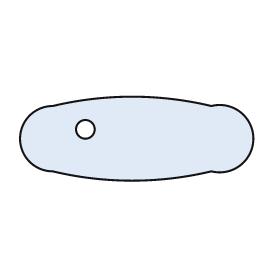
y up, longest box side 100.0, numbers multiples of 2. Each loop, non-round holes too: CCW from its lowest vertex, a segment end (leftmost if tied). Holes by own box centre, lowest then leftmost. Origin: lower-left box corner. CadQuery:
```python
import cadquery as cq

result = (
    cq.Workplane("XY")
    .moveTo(14.0, 4.0)
    .threePointArc((48.0, 0.0), (82.0, 4.0))
    .threePointArc((100.0, 18.0), (82.0, 32.0))
    .threePointArc((48.0, 36.0), (14.0, 32.0))
    .threePointArc((0.0, 18.0), (14.0, 4.0))
    .close()
    .moveTo(28.0, 22.0)
    .circle(4.0)
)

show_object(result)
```